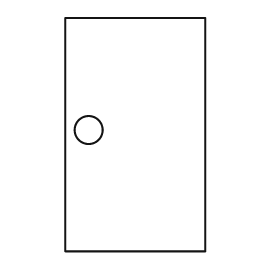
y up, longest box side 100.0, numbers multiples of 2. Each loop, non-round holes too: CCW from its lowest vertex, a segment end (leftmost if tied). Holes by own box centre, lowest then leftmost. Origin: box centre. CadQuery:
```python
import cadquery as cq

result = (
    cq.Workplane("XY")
    .moveTo(-30.0, -50.0)
    .lineTo(30.0, -50.0)
    .lineTo(30.0, 50.0)
    .lineTo(-30.0, 50.0)
    .close()
    .moveTo(-20.0, 2.0)
    .circle(6.0)
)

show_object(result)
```